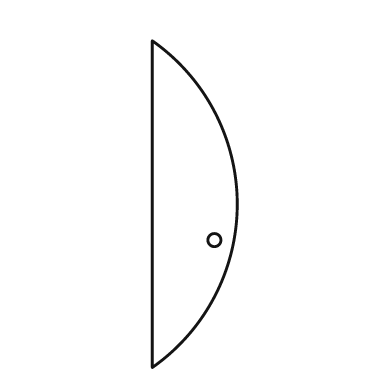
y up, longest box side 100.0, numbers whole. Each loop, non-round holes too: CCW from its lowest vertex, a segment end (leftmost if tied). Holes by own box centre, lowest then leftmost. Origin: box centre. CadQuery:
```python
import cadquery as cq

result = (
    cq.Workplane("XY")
    .moveTo(-13.0, -50.0)
    .threePointArc((13.0, 0.0), (-13.0, 50.0))
    .close()
    .moveTo(6.0, -11.0)
    .circle(2.0)
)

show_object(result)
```